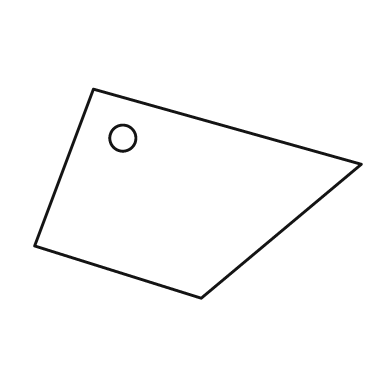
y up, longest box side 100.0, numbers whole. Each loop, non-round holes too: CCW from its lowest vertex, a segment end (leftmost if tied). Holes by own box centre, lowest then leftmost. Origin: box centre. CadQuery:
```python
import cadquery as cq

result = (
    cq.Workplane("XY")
    .moveTo(1.0, -32.0)
    .lineTo(50.0, 9.0)
    .lineTo(-32.0, 32.0)
    .lineTo(-50.0, -16.0)
    .close()
    .moveTo(-23.0, 17.0)
    .circle(4.0)
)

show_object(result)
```